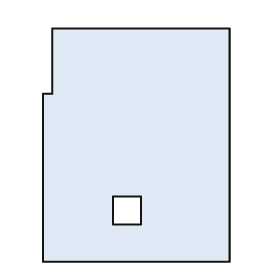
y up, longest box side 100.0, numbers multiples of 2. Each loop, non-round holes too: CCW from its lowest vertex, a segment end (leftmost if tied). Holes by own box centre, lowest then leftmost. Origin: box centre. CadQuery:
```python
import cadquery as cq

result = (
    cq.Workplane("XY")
    .moveTo(-40.0, -50.0)
    .lineTo(40.0, -50.0)
    .lineTo(40.0, 50.0)
    .lineTo(-36.0, 50.0)
    .lineTo(-36.0, 22.0)
    .lineTo(-40.0, 22.0)
    .close()
    .moveTo(-10.0, -34.0)
    .lineTo(2.0, -34.0)
    .lineTo(2.0, -22.0)
    .lineTo(-10.0, -22.0)
    .close()
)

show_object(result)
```